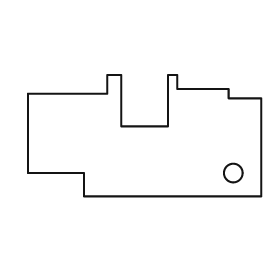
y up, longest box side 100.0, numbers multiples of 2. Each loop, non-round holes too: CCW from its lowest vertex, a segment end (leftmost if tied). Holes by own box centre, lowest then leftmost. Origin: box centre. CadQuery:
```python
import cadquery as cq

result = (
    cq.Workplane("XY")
    .moveTo(-26.0, -26.0)
    .lineTo(50.0, -26.0)
    .lineTo(50.0, 16.0)
    .lineTo(36.0, 16.0)
    .lineTo(36.0, 20.0)
    .lineTo(14.0, 20.0)
    .lineTo(14.0, 26.0)
    .lineTo(10.0, 26.0)
    .lineTo(10.0, 4.0)
    .lineTo(-10.0, 4.0)
    .lineTo(-10.0, 26.0)
    .lineTo(-16.0, 26.0)
    .lineTo(-16.0, 18.0)
    .lineTo(-50.0, 18.0)
    .lineTo(-50.0, -16.0)
    .lineTo(-26.0, -16.0)
    .close()
    .moveTo(38.0, -16.0)
    .circle(4.0)
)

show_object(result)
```